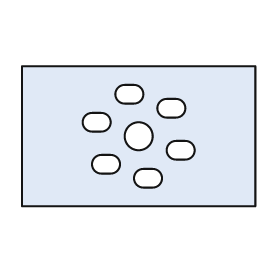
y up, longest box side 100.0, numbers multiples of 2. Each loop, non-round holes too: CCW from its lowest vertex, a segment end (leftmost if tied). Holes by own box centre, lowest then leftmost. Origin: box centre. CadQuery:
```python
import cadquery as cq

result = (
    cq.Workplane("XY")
    .moveTo(-50.0, -30.0)
    .lineTo(50.0, -30.0)
    .lineTo(50.0, 30.0)
    .lineTo(-50.0, 30.0)
    .close()
    .moveTo(2.0, -22.0)
    .lineTo(6.0, -22.0)
    .threePointArc((10.0, -18.0), (6.0, -14.0))
    .lineTo(2.0, -14.0)
    .threePointArc((-2.0, -18.0), (2.0, -22.0))
    .close()
    .moveTo(-16.0, -16.0)
    .lineTo(-12.0, -16.0)
    .threePointArc((-8.0, -12.0), (-12.0, -8.0))
    .lineTo(-16.0, -8.0)
    .threePointArc((-20.0, -12.0), (-16.0, -16.0))
    .close()
    .moveTo(16.0, -10.0)
    .lineTo(20.0, -10.0)
    .threePointArc((24.0, -6.0), (20.0, -2.0))
    .lineTo(16.0, -2.0)
    .threePointArc((12.0, -6.0), (16.0, -10.0))
    .close()
    .moveTo(0.0, 0.0)
    .circle(6.0)
    .moveTo(-20.0, 2.0)
    .lineTo(-16.0, 2.0)
    .threePointArc((-12.0, 6.0), (-16.0, 10.0))
    .lineTo(-20.0, 10.0)
    .threePointArc((-24.0, 6.0), (-20.0, 2.0))
    .close()
    .moveTo(12.0, 8.0)
    .lineTo(16.0, 8.0)
    .threePointArc((20.0, 12.0), (16.0, 16.0))
    .lineTo(12.0, 16.0)
    .threePointArc((8.0, 12.0), (12.0, 8.0))
    .close()
    .moveTo(-6.0, 14.0)
    .lineTo(-2.0, 14.0)
    .threePointArc((2.0, 18.0), (-2.0, 22.0))
    .lineTo(-6.0, 22.0)
    .threePointArc((-10.0, 18.0), (-6.0, 14.0))
    .close()
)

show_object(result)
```